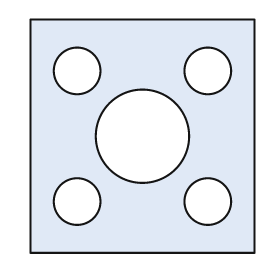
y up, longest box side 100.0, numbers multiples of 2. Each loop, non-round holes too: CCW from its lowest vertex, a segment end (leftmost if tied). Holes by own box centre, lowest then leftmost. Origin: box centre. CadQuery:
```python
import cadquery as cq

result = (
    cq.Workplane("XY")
    .moveTo(-48.0, -50.0)
    .lineTo(48.0, -50.0)
    .lineTo(48.0, 50.0)
    .lineTo(-48.0, 50.0)
    .close()
    .moveTo(-28.0, -28.0)
    .circle(10.0)
    .moveTo(28.0, -28.0)
    .circle(10.0)
    .moveTo(0.0, 0.0)
    .circle(20.0)
    .moveTo(-28.0, 28.0)
    .circle(10.0)
    .moveTo(28.0, 28.0)
    .circle(10.0)
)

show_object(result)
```